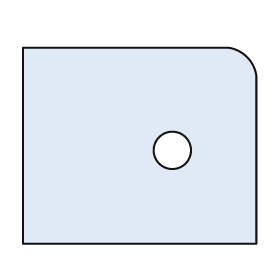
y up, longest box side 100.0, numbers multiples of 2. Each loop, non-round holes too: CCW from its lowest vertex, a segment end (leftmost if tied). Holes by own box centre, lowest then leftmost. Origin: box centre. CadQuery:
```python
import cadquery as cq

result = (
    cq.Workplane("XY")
    .moveTo(-50.0, -42.0)
    .lineTo(50.0, -42.0)
    .lineTo(50.0, 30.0)
    .threePointArc((46.0, 38.0), (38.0, 42.0))
    .lineTo(-50.0, 42.0)
    .close()
    .moveTo(14.0, -2.0)
    .circle(8.0)
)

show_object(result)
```